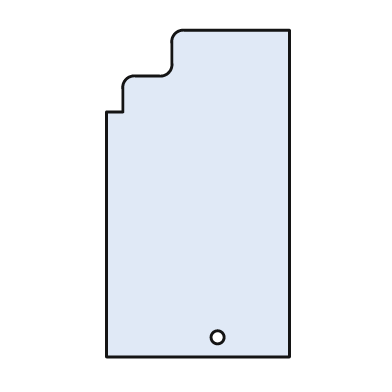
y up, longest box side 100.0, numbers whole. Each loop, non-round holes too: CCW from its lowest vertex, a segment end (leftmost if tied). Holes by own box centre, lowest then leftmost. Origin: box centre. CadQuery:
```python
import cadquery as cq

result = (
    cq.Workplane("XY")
    .moveTo(-28.0, -50.0)
    .lineTo(28.0, -50.0)
    .lineTo(28.0, 50.0)
    .lineTo(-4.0, 50.0)
    .threePointArc((-7.0, 49.0), (-8.0, 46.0))
    .lineTo(-8.0, 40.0)
    .threePointArc((-9.0, 37.0), (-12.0, 36.0))
    .lineTo(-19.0, 36.0)
    .threePointArc((-22.0, 35.0), (-23.0, 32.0))
    .lineTo(-23.0, 25.0)
    .lineTo(-28.0, 25.0)
    .close()
    .moveTo(6.0, -44.0)
    .circle(2.0)
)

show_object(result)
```